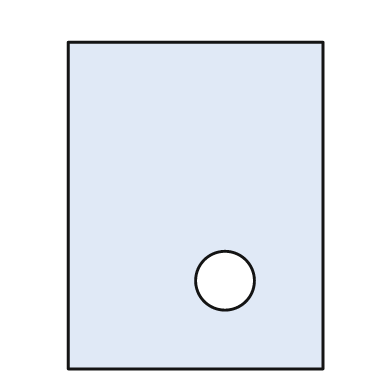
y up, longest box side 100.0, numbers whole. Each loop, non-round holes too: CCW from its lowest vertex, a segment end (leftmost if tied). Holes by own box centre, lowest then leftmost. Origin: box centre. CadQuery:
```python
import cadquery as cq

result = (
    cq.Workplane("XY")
    .moveTo(-39.0, -50.0)
    .lineTo(39.0, -50.0)
    .lineTo(39.0, 50.0)
    .lineTo(-39.0, 50.0)
    .close()
    .moveTo(9.0, -23.0)
    .circle(9.0)
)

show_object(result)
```